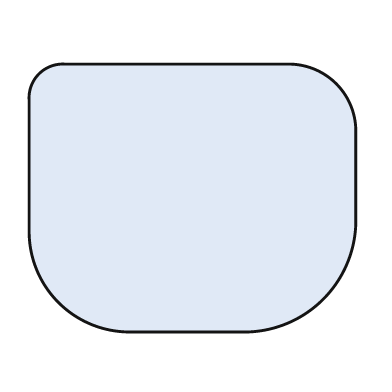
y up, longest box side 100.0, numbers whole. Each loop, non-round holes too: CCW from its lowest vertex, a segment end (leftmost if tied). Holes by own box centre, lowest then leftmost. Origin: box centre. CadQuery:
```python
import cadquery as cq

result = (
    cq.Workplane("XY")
    .moveTo(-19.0, -41.0)
    .lineTo(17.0, -41.0)
    .threePointArc((40.0, -31.0), (50.0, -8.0))
    .lineTo(50.0, 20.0)
    .threePointArc((44.0, 35.0), (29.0, 41.0))
    .lineTo(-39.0, 41.0)
    .threePointArc((-47.0, 38.0), (-50.0, 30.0))
    .lineTo(-50.0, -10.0)
    .threePointArc((-41.0, -32.0), (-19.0, -41.0))
    .close()
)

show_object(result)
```